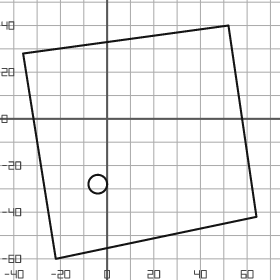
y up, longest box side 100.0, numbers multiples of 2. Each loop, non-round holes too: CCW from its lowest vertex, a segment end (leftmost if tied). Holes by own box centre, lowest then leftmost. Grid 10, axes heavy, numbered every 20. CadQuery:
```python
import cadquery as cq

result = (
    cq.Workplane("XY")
    .moveTo(-22.0, -60.0)
    .lineTo(64.0, -42.0)
    .lineTo(52.0, 40.0)
    .lineTo(-36.0, 28.0)
    .close()
    .moveTo(-4.0, -28.0)
    .circle(4.0)
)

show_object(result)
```